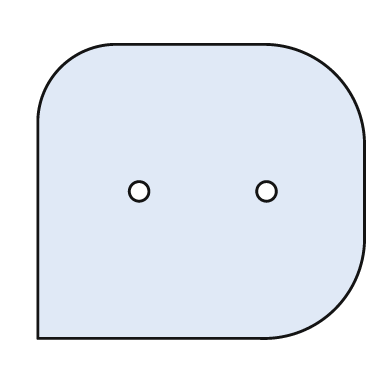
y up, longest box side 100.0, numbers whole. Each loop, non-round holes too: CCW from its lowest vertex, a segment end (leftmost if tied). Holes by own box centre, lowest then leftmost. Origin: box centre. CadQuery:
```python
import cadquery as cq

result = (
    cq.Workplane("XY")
    .moveTo(-50.0, -45.0)
    .lineTo(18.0, -45.0)
    .threePointArc((41.0, -36.0), (50.0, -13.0))
    .lineTo(50.0, 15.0)
    .threePointArc((41.0, 36.0), (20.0, 45.0))
    .lineTo(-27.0, 45.0)
    .threePointArc((-43.0, 38.0), (-50.0, 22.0))
    .close()
    .moveTo(-19.0, 0.0)
    .circle(3.0)
    .moveTo(20.0, 0.0)
    .circle(3.0)
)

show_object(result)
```